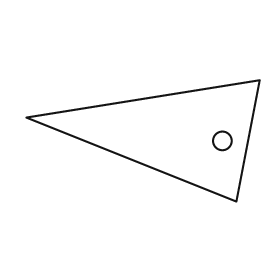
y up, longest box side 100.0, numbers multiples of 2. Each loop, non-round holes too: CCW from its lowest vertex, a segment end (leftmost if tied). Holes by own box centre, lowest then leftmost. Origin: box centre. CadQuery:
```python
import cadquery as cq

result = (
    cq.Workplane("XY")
    .moveTo(40.0, -26.0)
    .lineTo(50.0, 26.0)
    .lineTo(-50.0, 10.0)
    .close()
    .moveTo(34.0, 0.0)
    .circle(4.0)
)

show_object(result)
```